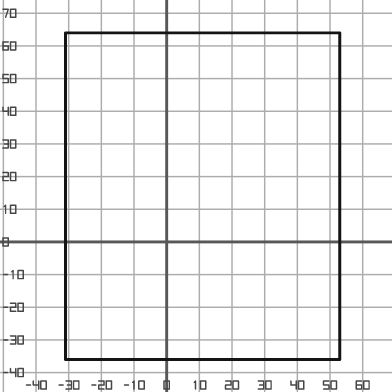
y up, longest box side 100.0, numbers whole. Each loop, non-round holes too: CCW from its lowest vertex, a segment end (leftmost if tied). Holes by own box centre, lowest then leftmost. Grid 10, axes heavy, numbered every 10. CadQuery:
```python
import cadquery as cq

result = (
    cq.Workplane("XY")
    .moveTo(-31.0, -36.0)
    .lineTo(53.0, -36.0)
    .lineTo(53.0, 64.0)
    .lineTo(-31.0, 64.0)
    .close()
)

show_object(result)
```